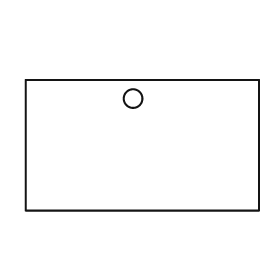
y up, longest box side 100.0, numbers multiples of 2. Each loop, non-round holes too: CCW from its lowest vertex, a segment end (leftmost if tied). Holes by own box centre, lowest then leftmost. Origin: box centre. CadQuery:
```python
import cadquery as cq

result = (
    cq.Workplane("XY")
    .moveTo(-50.0, -28.0)
    .lineTo(50.0, -28.0)
    .lineTo(50.0, 28.0)
    .lineTo(-50.0, 28.0)
    .close()
    .moveTo(-4.0, 20.0)
    .circle(4.0)
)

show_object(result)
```